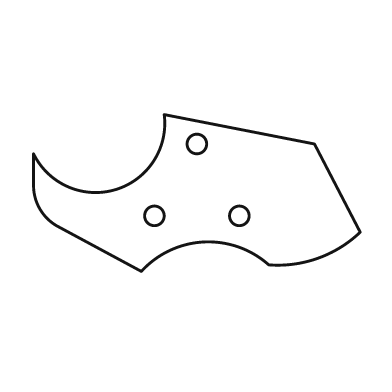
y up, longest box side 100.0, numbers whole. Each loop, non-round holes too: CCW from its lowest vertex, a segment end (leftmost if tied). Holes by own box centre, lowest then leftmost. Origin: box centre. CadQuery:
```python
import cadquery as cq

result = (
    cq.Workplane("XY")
    .moveTo(-17.0, -24.0)
    .threePointArc((2.0, -15.0), (22.0, -22.0))
    .threePointArc((37.0, -20.0), (50.0, -12.0))
    .lineTo(36.0, 15.0)
    .lineTo(-10.0, 24.0)
    .threePointArc((-25.0, 1.0), (-50.0, 12.0))
    .lineTo(-50.0, 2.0)
    .threePointArc((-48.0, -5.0), (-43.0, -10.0))
    .close()
    .moveTo(-13.0, -7.0)
    .circle(3.0)
    .moveTo(13.0, -7.0)
    .circle(3.0)
    .moveTo(0.0, 15.0)
    .circle(3.0)
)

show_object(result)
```